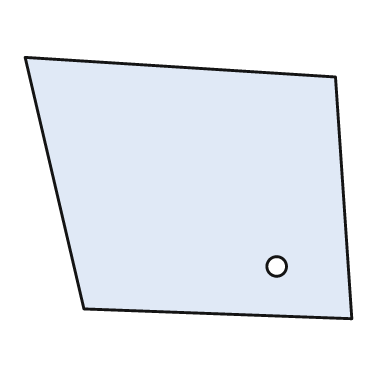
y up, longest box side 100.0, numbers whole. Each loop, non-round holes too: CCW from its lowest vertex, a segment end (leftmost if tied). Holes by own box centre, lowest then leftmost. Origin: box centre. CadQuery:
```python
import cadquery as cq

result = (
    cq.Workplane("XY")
    .moveTo(50.0, -40.0)
    .lineTo(45.0, 34.0)
    .lineTo(-50.0, 40.0)
    .lineTo(-32.0, -37.0)
    .close()
    .moveTo(27.0, -24.0)
    .circle(3.0)
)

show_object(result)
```